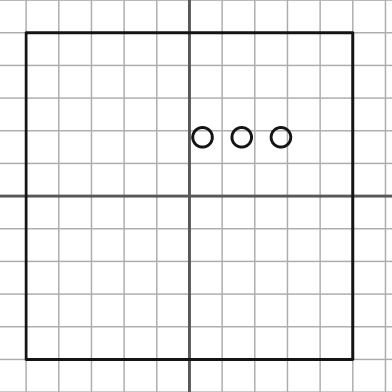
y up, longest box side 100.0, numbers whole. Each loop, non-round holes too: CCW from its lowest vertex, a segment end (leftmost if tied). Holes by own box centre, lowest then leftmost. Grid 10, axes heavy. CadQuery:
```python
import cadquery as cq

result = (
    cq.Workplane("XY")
    .moveTo(-50.0, -50.0)
    .lineTo(50.0, -50.0)
    .lineTo(50.0, 50.0)
    .lineTo(-50.0, 50.0)
    .close()
    .moveTo(4.0, 18.0)
    .circle(3.0)
    .moveTo(16.0, 18.0)
    .circle(3.0)
    .moveTo(28.0, 18.0)
    .circle(3.0)
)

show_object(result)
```